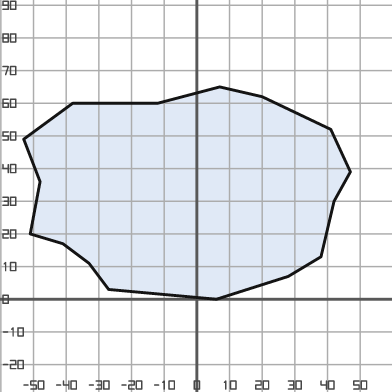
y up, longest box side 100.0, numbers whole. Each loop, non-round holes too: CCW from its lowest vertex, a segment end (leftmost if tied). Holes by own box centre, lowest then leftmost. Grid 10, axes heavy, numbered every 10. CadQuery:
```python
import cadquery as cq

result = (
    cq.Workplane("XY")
    .moveTo(6.0, 0.0)
    .lineTo(28.0, 7.0)
    .lineTo(38.0, 13.0)
    .lineTo(42.0, 30.0)
    .lineTo(47.0, 39.0)
    .lineTo(41.0, 52.0)
    .lineTo(20.0, 62.0)
    .lineTo(7.0, 65.0)
    .lineTo(-12.0, 60.0)
    .lineTo(-38.0, 60.0)
    .lineTo(-53.0, 49.0)
    .lineTo(-48.0, 36.0)
    .lineTo(-51.0, 20.0)
    .lineTo(-41.0, 17.0)
    .lineTo(-33.0, 11.0)
    .lineTo(-27.0, 3.0)
    .close()
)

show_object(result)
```